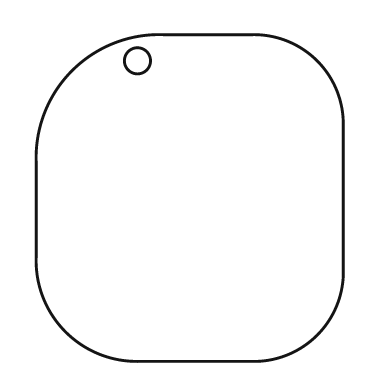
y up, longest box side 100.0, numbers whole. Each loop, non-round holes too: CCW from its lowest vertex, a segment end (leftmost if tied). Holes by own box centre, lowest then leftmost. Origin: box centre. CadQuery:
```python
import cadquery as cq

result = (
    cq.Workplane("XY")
    .moveTo(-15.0, -50.0)
    .lineTo(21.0, -50.0)
    .threePointArc((39.0, -42.0), (47.0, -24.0))
    .lineTo(47.0, 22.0)
    .threePointArc((39.0, 42.0), (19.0, 50.0))
    .lineTo(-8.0, 50.0)
    .threePointArc((-36.0, 39.0), (-47.0, 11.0))
    .lineTo(-47.0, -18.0)
    .threePointArc((-38.0, -41.0), (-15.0, -50.0))
    .close()
    .moveTo(-16.0, 42.0)
    .circle(4.0)
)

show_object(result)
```